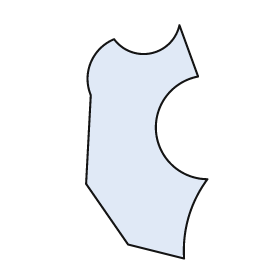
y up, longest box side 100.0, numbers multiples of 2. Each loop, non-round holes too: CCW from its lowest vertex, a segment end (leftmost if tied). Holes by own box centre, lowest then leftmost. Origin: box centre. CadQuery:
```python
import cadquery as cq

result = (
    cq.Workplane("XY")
    .moveTo(16.0, -50.0)
    .threePointArc((18.0, -32.0), (26.0, -16.0))
    .threePointArc((4.0, 4.0), (22.0, 28.0))
    .lineTo(14.0, 50.0)
    .threePointArc((2.0, 38.0), (-14.0, 44.0))
    .threePointArc((-24.0, 34.0), (-24.0, 20.0))
    .lineTo(-26.0, -18.0)
    .lineTo(-8.0, -44.0)
    .close()
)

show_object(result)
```